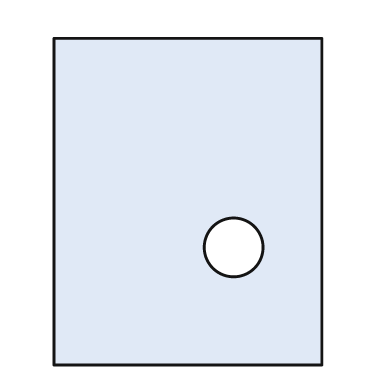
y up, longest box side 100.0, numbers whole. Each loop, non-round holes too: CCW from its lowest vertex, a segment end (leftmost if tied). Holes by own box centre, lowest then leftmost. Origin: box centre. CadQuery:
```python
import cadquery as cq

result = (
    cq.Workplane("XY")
    .moveTo(-41.0, -50.0)
    .lineTo(41.0, -50.0)
    .lineTo(41.0, 50.0)
    .lineTo(-41.0, 50.0)
    .close()
    .moveTo(14.0, -14.0)
    .circle(9.0)
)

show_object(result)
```